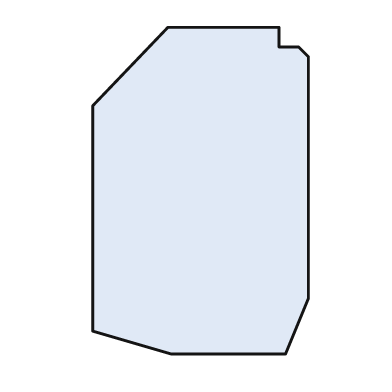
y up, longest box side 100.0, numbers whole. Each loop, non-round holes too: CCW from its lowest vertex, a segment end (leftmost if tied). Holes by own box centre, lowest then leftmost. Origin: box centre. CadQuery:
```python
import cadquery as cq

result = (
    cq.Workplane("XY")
    .moveTo(-9.0, -50.0)
    .lineTo(26.0, -50.0)
    .lineTo(33.0, -33.0)
    .lineTo(33.0, 41.0)
    .lineTo(30.0, 44.0)
    .lineTo(24.0, 44.0)
    .lineTo(24.0, 50.0)
    .lineTo(-10.0, 50.0)
    .lineTo(-33.0, 26.0)
    .lineTo(-33.0, -43.0)
    .close()
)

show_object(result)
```